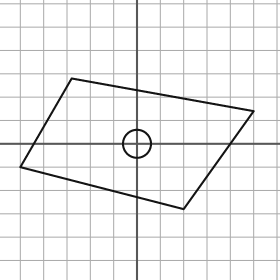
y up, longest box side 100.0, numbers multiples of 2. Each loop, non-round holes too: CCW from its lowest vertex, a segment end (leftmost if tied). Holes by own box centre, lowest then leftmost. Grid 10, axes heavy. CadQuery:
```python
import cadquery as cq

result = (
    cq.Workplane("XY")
    .moveTo(20.0, -28.0)
    .lineTo(50.0, 14.0)
    .lineTo(-28.0, 28.0)
    .lineTo(-50.0, -10.0)
    .close()
    .moveTo(0.0, 0.0)
    .circle(6.0)
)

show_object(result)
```